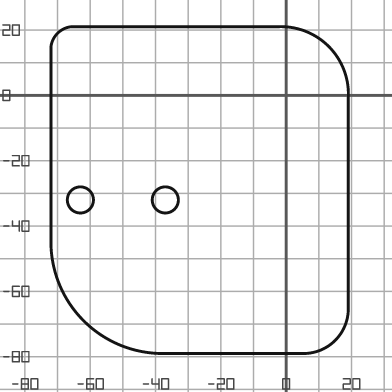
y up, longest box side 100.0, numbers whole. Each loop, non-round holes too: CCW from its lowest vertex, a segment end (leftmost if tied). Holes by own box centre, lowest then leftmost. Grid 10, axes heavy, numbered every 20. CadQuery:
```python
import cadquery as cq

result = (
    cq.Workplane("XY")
    .moveTo(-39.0, -79.0)
    .lineTo(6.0, -79.0)
    .threePointArc((15.0, -75.0), (19.0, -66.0))
    .lineTo(19.0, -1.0)
    .threePointArc((13.0, 15.0), (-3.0, 21.0))
    .lineTo(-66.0, 21.0)
    .threePointArc((-70.0, 19.0), (-72.0, 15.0))
    .lineTo(-72.0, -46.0)
    .threePointArc((-62.0, -69.0), (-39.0, -79.0))
    .close()
    .moveTo(-63.0, -32.0)
    .circle(4.0)
    .moveTo(-37.0, -32.0)
    .circle(4.0)
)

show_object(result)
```